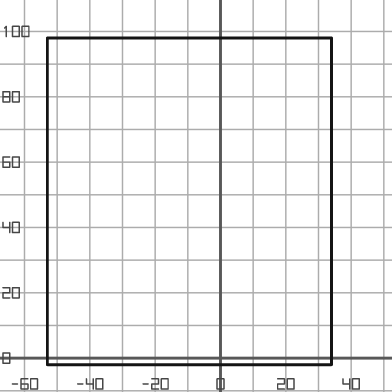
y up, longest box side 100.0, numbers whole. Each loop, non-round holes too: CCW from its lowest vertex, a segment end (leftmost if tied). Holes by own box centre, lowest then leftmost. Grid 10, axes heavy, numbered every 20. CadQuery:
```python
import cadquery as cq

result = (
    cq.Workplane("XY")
    .moveTo(-53.0, -2.0)
    .lineTo(34.0, -2.0)
    .lineTo(34.0, 98.0)
    .lineTo(-53.0, 98.0)
    .close()
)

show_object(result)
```